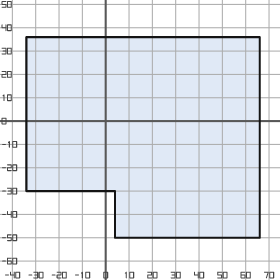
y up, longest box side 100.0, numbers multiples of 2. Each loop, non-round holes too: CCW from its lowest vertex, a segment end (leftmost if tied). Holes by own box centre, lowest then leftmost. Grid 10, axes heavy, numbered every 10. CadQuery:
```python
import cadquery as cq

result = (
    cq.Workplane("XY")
    .moveTo(4.0, -50.0)
    .lineTo(66.0, -50.0)
    .lineTo(66.0, 36.0)
    .lineTo(-34.0, 36.0)
    .lineTo(-34.0, -30.0)
    .lineTo(4.0, -30.0)
    .close()
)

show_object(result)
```